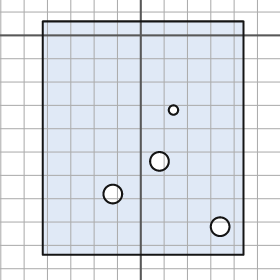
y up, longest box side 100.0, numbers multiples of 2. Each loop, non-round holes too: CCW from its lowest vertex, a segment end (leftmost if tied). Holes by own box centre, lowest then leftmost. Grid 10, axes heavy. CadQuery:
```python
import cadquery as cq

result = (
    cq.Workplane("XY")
    .moveTo(-42.0, -94.0)
    .lineTo(44.0, -94.0)
    .lineTo(44.0, 6.0)
    .lineTo(-42.0, 6.0)
    .close()
    .moveTo(34.0, -82.0)
    .circle(4.0)
    .moveTo(-12.0, -68.0)
    .circle(4.0)
    .moveTo(8.0, -54.0)
    .circle(4.0)
    .moveTo(14.0, -32.0)
    .circle(2.0)
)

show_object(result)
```